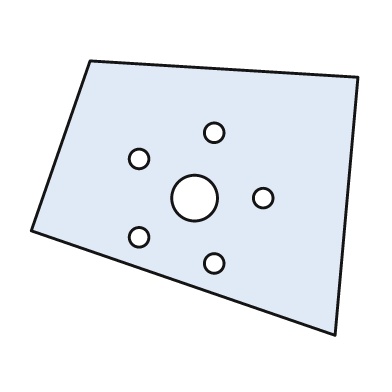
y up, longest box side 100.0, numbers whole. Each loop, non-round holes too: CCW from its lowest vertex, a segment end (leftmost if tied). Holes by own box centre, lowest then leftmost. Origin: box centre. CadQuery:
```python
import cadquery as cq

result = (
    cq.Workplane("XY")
    .moveTo(43.0, -42.0)
    .lineTo(50.0, 37.0)
    .lineTo(-32.0, 42.0)
    .lineTo(-50.0, -10.0)
    .close()
    .moveTo(6.0, -20.0)
    .circle(3.0)
    .moveTo(-17.0, -12.0)
    .circle(3.0)
    .moveTo(0.0, 0.0)
    .circle(7.0)
    .moveTo(21.0, 0.0)
    .circle(3.0)
    .moveTo(-17.0, 12.0)
    .circle(3.0)
    .moveTo(6.0, 20.0)
    .circle(3.0)
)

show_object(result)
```